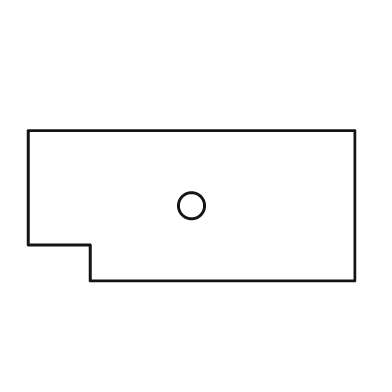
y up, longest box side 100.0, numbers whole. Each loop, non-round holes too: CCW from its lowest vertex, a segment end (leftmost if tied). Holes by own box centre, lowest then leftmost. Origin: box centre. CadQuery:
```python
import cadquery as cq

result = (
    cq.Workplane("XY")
    .moveTo(-31.0, -23.0)
    .lineTo(50.0, -23.0)
    .lineTo(50.0, 23.0)
    .lineTo(-50.0, 23.0)
    .lineTo(-50.0, -12.0)
    .lineTo(-31.0, -12.0)
    .close()
    .moveTo(0.0, 0.0)
    .circle(4.0)
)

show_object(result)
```